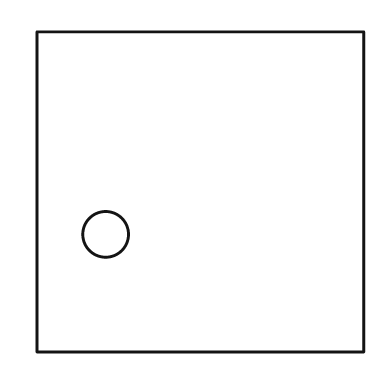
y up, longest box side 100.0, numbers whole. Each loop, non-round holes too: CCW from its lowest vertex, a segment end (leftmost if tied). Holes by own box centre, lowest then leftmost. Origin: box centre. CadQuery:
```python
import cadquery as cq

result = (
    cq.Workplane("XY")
    .moveTo(-50.0, -49.0)
    .lineTo(50.0, -49.0)
    .lineTo(50.0, 49.0)
    .lineTo(-50.0, 49.0)
    .close()
    .moveTo(-29.0, -13.0)
    .circle(7.0)
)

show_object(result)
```